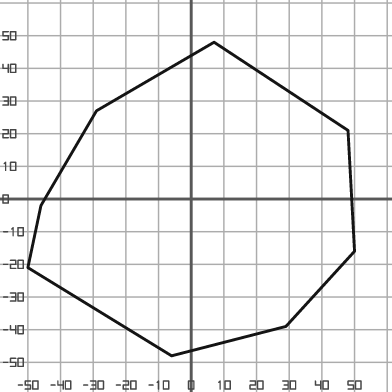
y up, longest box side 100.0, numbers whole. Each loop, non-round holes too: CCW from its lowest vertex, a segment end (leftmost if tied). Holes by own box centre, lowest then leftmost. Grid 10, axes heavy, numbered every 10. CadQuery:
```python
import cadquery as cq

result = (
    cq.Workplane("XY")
    .moveTo(-6.0, -48.0)
    .lineTo(29.0, -39.0)
    .lineTo(50.0, -16.0)
    .lineTo(48.0, 21.0)
    .lineTo(7.0, 48.0)
    .lineTo(-29.0, 27.0)
    .lineTo(-46.0, -2.0)
    .lineTo(-50.0, -21.0)
    .close()
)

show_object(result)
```